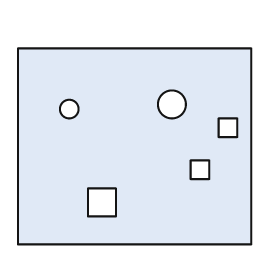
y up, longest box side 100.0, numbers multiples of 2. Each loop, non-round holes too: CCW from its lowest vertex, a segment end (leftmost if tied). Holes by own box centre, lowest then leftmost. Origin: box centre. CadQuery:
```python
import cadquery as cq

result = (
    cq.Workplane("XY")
    .moveTo(-50.0, -42.0)
    .lineTo(50.0, -42.0)
    .lineTo(50.0, 42.0)
    .lineTo(-50.0, 42.0)
    .close()
    .moveTo(-20.0, -30.0)
    .lineTo(-8.0, -30.0)
    .lineTo(-8.0, -18.0)
    .lineTo(-20.0, -18.0)
    .close()
    .moveTo(24.0, -14.0)
    .lineTo(32.0, -14.0)
    .lineTo(32.0, -6.0)
    .lineTo(24.0, -6.0)
    .close()
    .moveTo(36.0, 4.0)
    .lineTo(44.0, 4.0)
    .lineTo(44.0, 12.0)
    .lineTo(36.0, 12.0)
    .close()
    .moveTo(-28.0, 16.0)
    .circle(4.0)
    .moveTo(16.0, 18.0)
    .circle(6.0)
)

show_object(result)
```